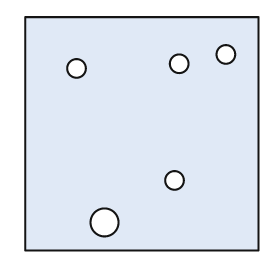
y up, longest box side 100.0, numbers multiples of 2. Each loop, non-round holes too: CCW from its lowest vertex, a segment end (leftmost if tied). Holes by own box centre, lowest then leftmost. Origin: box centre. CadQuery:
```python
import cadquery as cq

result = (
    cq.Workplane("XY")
    .moveTo(-50.0, -50.0)
    .lineTo(50.0, -50.0)
    .lineTo(50.0, 50.0)
    .lineTo(-50.0, 50.0)
    .close()
    .moveTo(-16.0, -38.0)
    .circle(6.0)
    .moveTo(14.0, -20.0)
    .circle(4.0)
    .moveTo(-28.0, 28.0)
    .circle(4.0)
    .moveTo(16.0, 30.0)
    .circle(4.0)
    .moveTo(36.0, 34.0)
    .circle(4.0)
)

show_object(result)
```